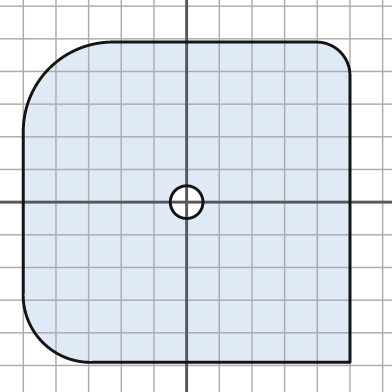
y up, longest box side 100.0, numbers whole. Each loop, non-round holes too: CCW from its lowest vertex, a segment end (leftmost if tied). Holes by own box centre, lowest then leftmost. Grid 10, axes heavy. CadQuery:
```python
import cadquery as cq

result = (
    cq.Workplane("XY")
    .moveTo(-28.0, -49.0)
    .lineTo(50.0, -49.0)
    .lineTo(50.0, 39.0)
    .threePointArc((47.0, 46.0), (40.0, 49.0))
    .lineTo(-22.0, 49.0)
    .threePointArc((-42.0, 41.0), (-50.0, 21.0))
    .lineTo(-50.0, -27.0)
    .threePointArc((-44.0, -43.0), (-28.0, -49.0))
    .close()
    .moveTo(0.0, 0.0)
    .circle(5.0)
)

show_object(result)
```